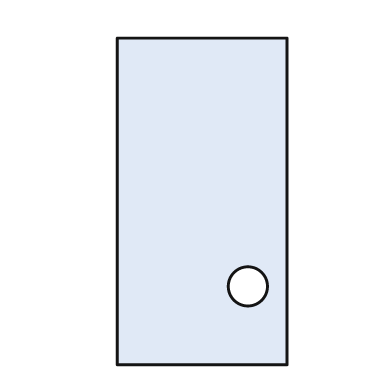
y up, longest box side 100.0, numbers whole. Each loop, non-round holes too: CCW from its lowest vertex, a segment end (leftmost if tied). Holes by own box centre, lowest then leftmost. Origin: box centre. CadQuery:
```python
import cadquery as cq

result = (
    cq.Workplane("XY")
    .moveTo(-26.0, -50.0)
    .lineTo(26.0, -50.0)
    .lineTo(26.0, 50.0)
    .lineTo(-26.0, 50.0)
    .close()
    .moveTo(14.0, -26.0)
    .circle(6.0)
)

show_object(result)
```